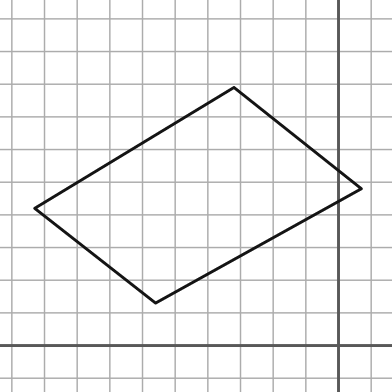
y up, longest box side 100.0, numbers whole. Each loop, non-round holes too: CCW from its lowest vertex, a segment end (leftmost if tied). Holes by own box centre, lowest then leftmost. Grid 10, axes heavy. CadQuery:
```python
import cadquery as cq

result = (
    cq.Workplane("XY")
    .moveTo(-56.0, 13.0)
    .lineTo(7.0, 48.0)
    .lineTo(-32.0, 79.0)
    .lineTo(-93.0, 42.0)
    .close()
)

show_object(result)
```